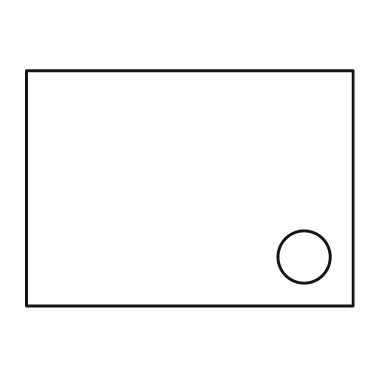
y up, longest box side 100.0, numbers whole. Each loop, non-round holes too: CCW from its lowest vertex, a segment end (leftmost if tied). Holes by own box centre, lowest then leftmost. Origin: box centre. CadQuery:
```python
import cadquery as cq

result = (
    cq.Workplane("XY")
    .moveTo(-50.0, -36.0)
    .lineTo(50.0, -36.0)
    .lineTo(50.0, 36.0)
    .lineTo(-50.0, 36.0)
    .close()
    .moveTo(35.0, -21.0)
    .circle(8.0)
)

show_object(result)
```